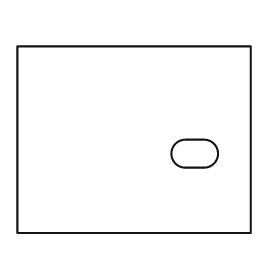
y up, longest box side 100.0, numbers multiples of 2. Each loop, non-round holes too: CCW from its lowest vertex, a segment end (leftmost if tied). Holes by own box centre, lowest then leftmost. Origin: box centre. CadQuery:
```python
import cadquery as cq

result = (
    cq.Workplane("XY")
    .moveTo(-50.0, -40.0)
    .lineTo(50.0, -40.0)
    .lineTo(50.0, 40.0)
    .lineTo(-50.0, 40.0)
    .close()
    .moveTo(22.0, -12.0)
    .lineTo(30.0, -12.0)
    .threePointArc((36.0, -6.0), (30.0, 0.0))
    .lineTo(22.0, 0.0)
    .threePointArc((16.0, -6.0), (22.0, -12.0))
    .close()
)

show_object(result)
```